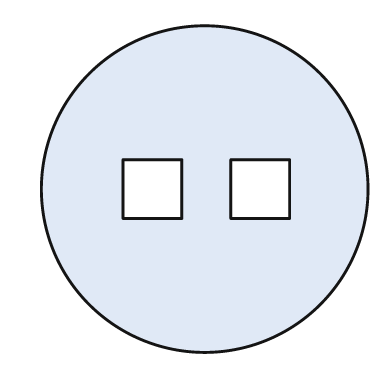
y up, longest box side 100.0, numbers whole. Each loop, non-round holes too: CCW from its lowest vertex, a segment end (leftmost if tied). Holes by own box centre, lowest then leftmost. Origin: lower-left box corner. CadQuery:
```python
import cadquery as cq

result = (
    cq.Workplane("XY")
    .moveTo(50.0, 50.0)
    .circle(50.0)
    .moveTo(25.0, 41.0)
    .lineTo(43.0, 41.0)
    .lineTo(43.0, 59.0)
    .lineTo(25.0, 59.0)
    .close()
    .moveTo(58.0, 41.0)
    .lineTo(76.0, 41.0)
    .lineTo(76.0, 59.0)
    .lineTo(58.0, 59.0)
    .close()
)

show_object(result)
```